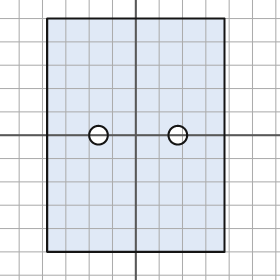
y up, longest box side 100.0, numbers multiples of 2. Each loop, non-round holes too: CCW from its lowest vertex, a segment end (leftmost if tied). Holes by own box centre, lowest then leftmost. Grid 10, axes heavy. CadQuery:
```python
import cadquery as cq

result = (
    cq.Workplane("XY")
    .moveTo(-38.0, -50.0)
    .lineTo(38.0, -50.0)
    .lineTo(38.0, 50.0)
    .lineTo(-38.0, 50.0)
    .close()
    .moveTo(-16.0, 0.0)
    .circle(4.0)
    .moveTo(18.0, 0.0)
    .circle(4.0)
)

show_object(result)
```